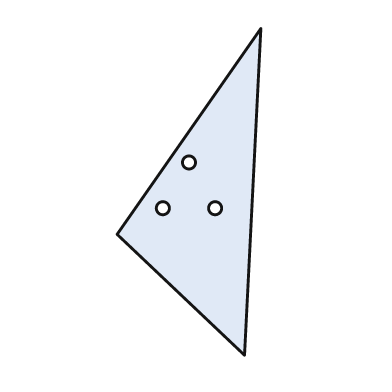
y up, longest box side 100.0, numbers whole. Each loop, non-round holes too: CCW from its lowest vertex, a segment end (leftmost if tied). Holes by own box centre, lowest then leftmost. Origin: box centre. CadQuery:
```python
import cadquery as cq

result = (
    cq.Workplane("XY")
    .moveTo(17.0, -50.0)
    .lineTo(22.0, 50.0)
    .lineTo(-22.0, -13.0)
    .close()
    .moveTo(-8.0, -5.0)
    .circle(2.0)
    .moveTo(8.0, -5.0)
    .circle(2.0)
    .moveTo(0.0, 9.0)
    .circle(2.0)
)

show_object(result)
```